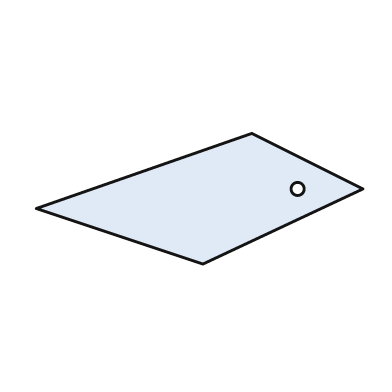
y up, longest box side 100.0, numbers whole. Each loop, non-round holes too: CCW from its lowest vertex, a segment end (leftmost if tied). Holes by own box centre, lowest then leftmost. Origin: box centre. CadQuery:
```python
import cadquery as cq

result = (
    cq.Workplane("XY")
    .moveTo(1.0, -20.0)
    .lineTo(50.0, 3.0)
    .lineTo(16.0, 20.0)
    .lineTo(-50.0, -3.0)
    .close()
    .moveTo(30.0, 3.0)
    .circle(2.0)
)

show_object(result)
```